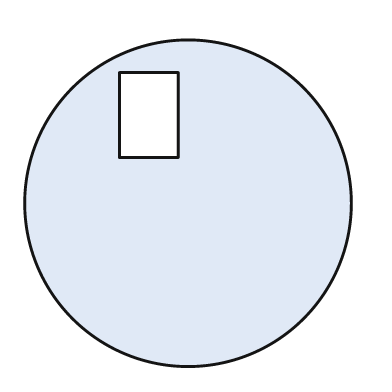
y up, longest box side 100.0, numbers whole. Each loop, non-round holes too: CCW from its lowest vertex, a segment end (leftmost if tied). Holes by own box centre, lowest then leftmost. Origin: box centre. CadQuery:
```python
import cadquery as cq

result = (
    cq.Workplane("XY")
    .moveTo(0.0, 0.0)
    .circle(50.0)
    .moveTo(-21.0, 14.0)
    .lineTo(-3.0, 14.0)
    .lineTo(-3.0, 40.0)
    .lineTo(-21.0, 40.0)
    .close()
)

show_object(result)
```